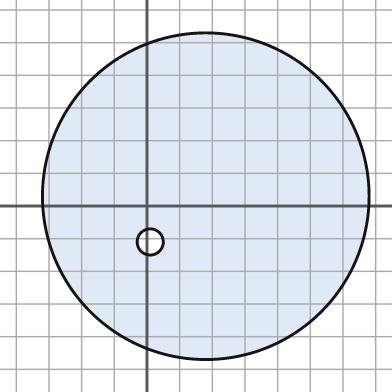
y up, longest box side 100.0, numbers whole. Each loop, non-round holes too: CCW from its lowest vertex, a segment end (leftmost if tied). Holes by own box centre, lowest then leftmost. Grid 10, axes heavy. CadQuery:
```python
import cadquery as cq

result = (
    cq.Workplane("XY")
    .moveTo(18.0, 3.0)
    .circle(50.0)
    .moveTo(1.0, -11.0)
    .circle(4.0)
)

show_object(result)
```